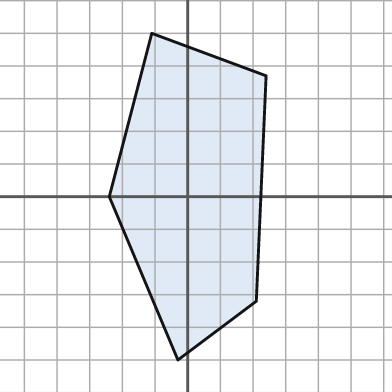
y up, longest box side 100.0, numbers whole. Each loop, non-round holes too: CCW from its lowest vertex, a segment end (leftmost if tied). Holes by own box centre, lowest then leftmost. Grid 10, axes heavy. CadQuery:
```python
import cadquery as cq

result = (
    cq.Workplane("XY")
    .moveTo(-3.0, -50.0)
    .lineTo(21.0, -32.0)
    .lineTo(24.0, 37.0)
    .lineTo(-11.0, 50.0)
    .lineTo(-24.0, 0.0)
    .close()
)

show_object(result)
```